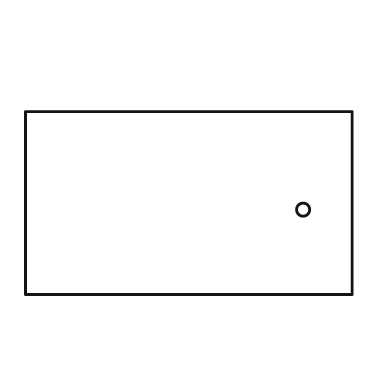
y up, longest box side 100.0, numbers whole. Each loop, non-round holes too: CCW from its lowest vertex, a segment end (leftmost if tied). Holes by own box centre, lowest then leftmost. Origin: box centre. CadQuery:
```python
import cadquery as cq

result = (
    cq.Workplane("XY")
    .moveTo(-50.0, -28.0)
    .lineTo(50.0, -28.0)
    .lineTo(50.0, 28.0)
    .lineTo(-50.0, 28.0)
    .close()
    .moveTo(35.0, -2.0)
    .circle(2.0)
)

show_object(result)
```